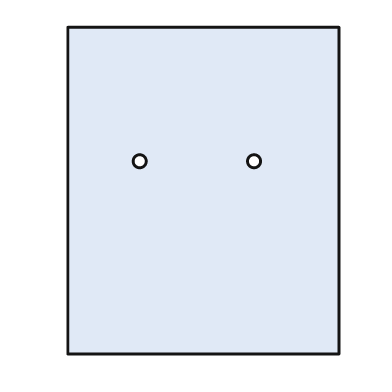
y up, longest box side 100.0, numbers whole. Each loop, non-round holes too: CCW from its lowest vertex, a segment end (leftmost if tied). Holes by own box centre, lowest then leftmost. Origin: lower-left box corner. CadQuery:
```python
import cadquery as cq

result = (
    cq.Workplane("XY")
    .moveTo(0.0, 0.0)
    .lineTo(83.0, 0.0)
    .lineTo(83.0, 100.0)
    .lineTo(0.0, 100.0)
    .close()
    .moveTo(22.0, 59.0)
    .circle(2.0)
    .moveTo(57.0, 59.0)
    .circle(2.0)
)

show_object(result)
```